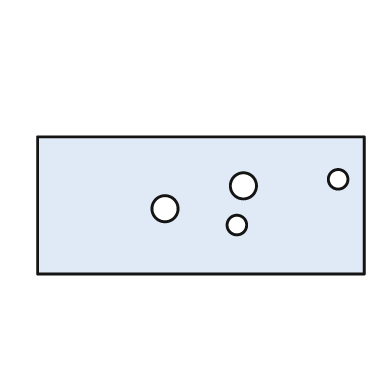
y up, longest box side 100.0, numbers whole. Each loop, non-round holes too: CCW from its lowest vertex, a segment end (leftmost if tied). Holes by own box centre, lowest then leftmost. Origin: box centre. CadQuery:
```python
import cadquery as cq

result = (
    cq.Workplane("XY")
    .moveTo(-50.0, -21.0)
    .lineTo(50.0, -21.0)
    .lineTo(50.0, 21.0)
    .lineTo(-50.0, 21.0)
    .close()
    .moveTo(11.0, -6.0)
    .circle(3.0)
    .moveTo(-11.0, -1.0)
    .circle(4.0)
    .moveTo(13.0, 6.0)
    .circle(4.0)
    .moveTo(42.0, 8.0)
    .circle(3.0)
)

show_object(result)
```